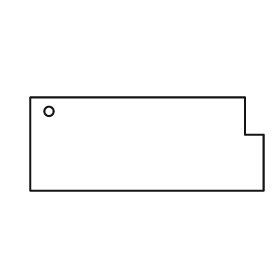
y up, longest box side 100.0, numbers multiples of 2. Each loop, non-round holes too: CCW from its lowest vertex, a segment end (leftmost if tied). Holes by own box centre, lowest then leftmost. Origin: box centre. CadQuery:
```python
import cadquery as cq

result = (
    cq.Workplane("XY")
    .moveTo(-50.0, -20.0)
    .lineTo(50.0, -20.0)
    .lineTo(50.0, 4.0)
    .lineTo(42.0, 4.0)
    .lineTo(42.0, 20.0)
    .lineTo(-50.0, 20.0)
    .close()
    .moveTo(-42.0, 14.0)
    .circle(2.0)
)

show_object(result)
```